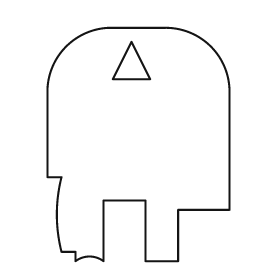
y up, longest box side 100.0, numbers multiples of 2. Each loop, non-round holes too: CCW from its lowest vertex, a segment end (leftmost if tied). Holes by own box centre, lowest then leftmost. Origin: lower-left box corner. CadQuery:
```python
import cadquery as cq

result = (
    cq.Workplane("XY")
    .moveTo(12.0, 0.0)
    .threePointArc((18.0, 2.0), (24.0, 0.0))
    .lineTo(24.0, 26.0)
    .lineTo(42.0, 26.0)
    .lineTo(42.0, 0.0)
    .lineTo(56.0, 0.0)
    .lineTo(56.0, 22.0)
    .lineTo(78.0, 22.0)
    .lineTo(78.0, 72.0)
    .threePointArc((70.0, 92.0), (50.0, 100.0))
    .lineTo(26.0, 100.0)
    .threePointArc((8.0, 92.0), (0.0, 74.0))
    .lineTo(0.0, 36.0)
    .lineTo(6.0, 36.0)
    .threePointArc((4.0, 20.0), (6.0, 4.0))
    .lineTo(12.0, 4.0)
    .close()
    .moveTo(28.0, 78.0)
    .lineTo(44.0, 78.0)
    .lineTo(36.0, 94.0)
    .close()
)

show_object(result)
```